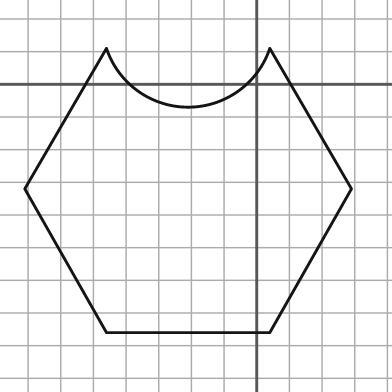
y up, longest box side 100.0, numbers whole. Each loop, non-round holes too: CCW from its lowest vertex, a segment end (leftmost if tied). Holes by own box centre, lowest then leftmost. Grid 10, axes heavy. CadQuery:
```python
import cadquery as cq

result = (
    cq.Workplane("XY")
    .moveTo(-46.0, -76.0)
    .lineTo(4.0, -76.0)
    .lineTo(29.0, -32.0)
    .lineTo(4.0, 11.0)
    .threePointArc((-21.0, -7.0), (-46.0, 11.0))
    .lineTo(-71.0, -32.0)
    .close()
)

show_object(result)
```